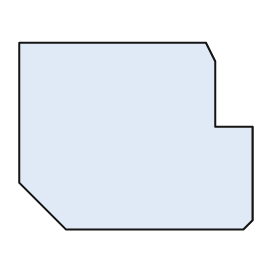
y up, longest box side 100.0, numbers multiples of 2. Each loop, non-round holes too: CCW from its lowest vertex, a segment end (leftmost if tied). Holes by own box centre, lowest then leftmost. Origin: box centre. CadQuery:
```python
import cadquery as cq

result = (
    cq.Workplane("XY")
    .moveTo(-30.0, -40.0)
    .lineTo(46.0, -40.0)
    .lineTo(50.0, -36.0)
    .lineTo(50.0, 4.0)
    .lineTo(34.0, 4.0)
    .lineTo(34.0, 32.0)
    .lineTo(30.0, 40.0)
    .lineTo(-50.0, 40.0)
    .lineTo(-50.0, -20.0)
    .close()
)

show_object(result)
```